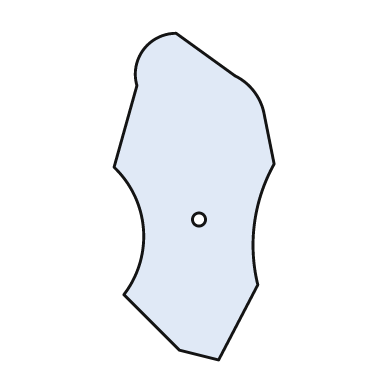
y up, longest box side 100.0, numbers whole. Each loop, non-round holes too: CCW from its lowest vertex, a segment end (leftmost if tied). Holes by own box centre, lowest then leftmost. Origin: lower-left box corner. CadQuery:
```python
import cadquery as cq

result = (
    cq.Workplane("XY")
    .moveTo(32.0, 0.0)
    .lineTo(44.0, 23.0)
    .threePointArc((43.0, 42.0), (49.0, 60.0))
    .lineTo(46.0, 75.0)
    .threePointArc((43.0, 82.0), (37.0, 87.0))
    .lineTo(19.0, 100.0)
    .threePointArc((9.0, 95.0), (7.0, 84.0))
    .lineTo(0.0, 59.0)
    .threePointArc((9.0, 40.0), (3.0, 20.0))
    .lineTo(20.0, 3.0)
    .close()
    .moveTo(26.0, 43.0)
    .circle(2.0)
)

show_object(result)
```